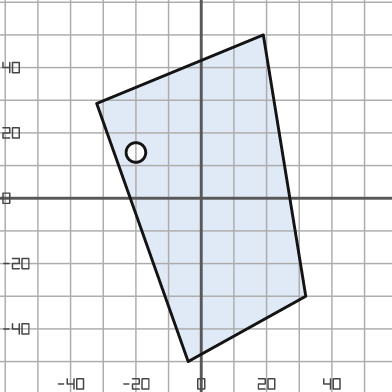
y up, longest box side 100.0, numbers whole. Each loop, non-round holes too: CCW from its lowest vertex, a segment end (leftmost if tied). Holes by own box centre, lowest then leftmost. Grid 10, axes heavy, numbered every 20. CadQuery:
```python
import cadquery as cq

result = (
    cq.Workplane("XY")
    .moveTo(-4.0, -50.0)
    .lineTo(32.0, -30.0)
    .lineTo(19.0, 50.0)
    .lineTo(-32.0, 29.0)
    .close()
    .moveTo(-20.0, 14.0)
    .circle(3.0)
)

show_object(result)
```